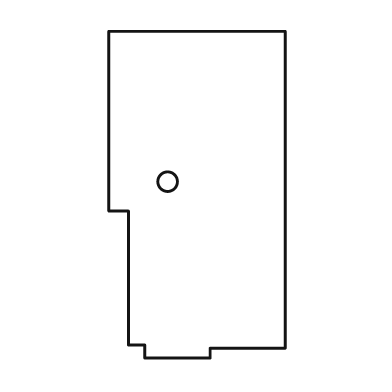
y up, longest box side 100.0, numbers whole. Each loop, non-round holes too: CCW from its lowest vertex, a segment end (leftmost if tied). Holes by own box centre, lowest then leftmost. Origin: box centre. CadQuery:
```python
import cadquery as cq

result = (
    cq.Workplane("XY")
    .moveTo(-16.0, -50.0)
    .lineTo(4.0, -50.0)
    .lineTo(4.0, -47.0)
    .lineTo(27.0, -47.0)
    .lineTo(27.0, 50.0)
    .lineTo(-27.0, 50.0)
    .lineTo(-27.0, -5.0)
    .lineTo(-21.0, -5.0)
    .lineTo(-21.0, -46.0)
    .lineTo(-16.0, -46.0)
    .close()
    .moveTo(-9.0, 4.0)
    .circle(3.0)
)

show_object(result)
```